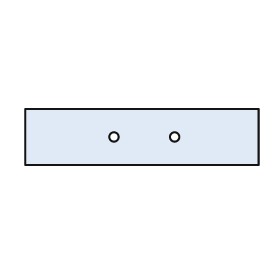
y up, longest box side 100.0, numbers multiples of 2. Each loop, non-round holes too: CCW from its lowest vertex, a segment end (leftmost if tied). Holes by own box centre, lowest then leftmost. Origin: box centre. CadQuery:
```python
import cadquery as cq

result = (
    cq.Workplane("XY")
    .moveTo(-50.0, -12.0)
    .lineTo(50.0, -12.0)
    .lineTo(50.0, 12.0)
    .lineTo(-50.0, 12.0)
    .close()
    .moveTo(-12.0, 0.0)
    .circle(2.0)
    .moveTo(14.0, 0.0)
    .circle(2.0)
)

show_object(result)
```